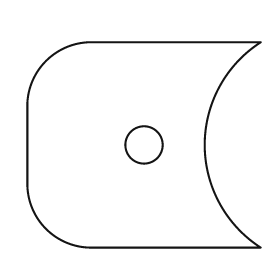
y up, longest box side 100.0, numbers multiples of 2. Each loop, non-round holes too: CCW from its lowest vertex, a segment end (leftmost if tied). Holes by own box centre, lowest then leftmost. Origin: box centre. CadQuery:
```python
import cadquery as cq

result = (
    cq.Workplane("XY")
    .moveTo(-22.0, -44.0)
    .lineTo(50.0, -44.0)
    .threePointArc((26.0, 0.0), (50.0, 44.0))
    .lineTo(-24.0, 44.0)
    .threePointArc((-42.0, 36.0), (-50.0, 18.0))
    .lineTo(-50.0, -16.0)
    .threePointArc((-42.0, -36.0), (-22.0, -44.0))
    .close()
    .moveTo(0.0, 0.0)
    .circle(8.0)
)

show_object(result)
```